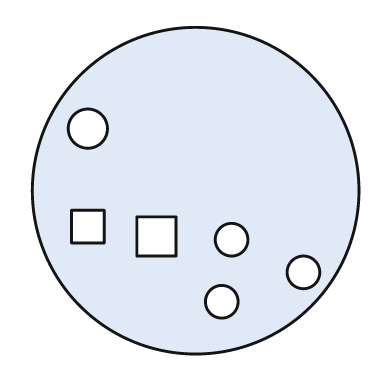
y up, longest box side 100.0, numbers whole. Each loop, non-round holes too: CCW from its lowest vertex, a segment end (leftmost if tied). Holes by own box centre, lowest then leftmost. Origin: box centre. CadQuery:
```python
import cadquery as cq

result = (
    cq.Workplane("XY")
    .moveTo(0.0, 0.0)
    .circle(50.0)
    .moveTo(8.0, -34.0)
    .circle(5.0)
    .moveTo(33.0, -25.0)
    .circle(5.0)
    .moveTo(11.0, -15.0)
    .circle(5.0)
    .moveTo(-18.0, -20.0)
    .lineTo(-6.0, -20.0)
    .lineTo(-6.0, -8.0)
    .lineTo(-18.0, -8.0)
    .close()
    .moveTo(-38.0, -16.0)
    .lineTo(-28.0, -16.0)
    .lineTo(-28.0, -6.0)
    .lineTo(-38.0, -6.0)
    .close()
    .moveTo(-33.0, 19.0)
    .circle(6.0)
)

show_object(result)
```